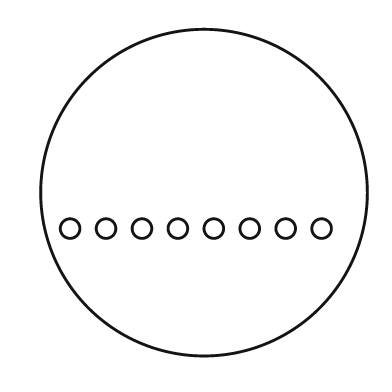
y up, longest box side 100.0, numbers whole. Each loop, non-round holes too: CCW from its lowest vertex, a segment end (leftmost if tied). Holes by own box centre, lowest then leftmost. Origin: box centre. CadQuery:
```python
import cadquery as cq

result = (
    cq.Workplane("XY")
    .moveTo(0.0, 0.0)
    .circle(50.0)
    .moveTo(-41.0, -11.0)
    .circle(3.0)
    .moveTo(-30.0, -11.0)
    .circle(3.0)
    .moveTo(-19.0, -11.0)
    .circle(3.0)
    .moveTo(-8.0, -11.0)
    .circle(3.0)
    .moveTo(3.0, -11.0)
    .circle(3.0)
    .moveTo(14.0, -11.0)
    .circle(3.0)
    .moveTo(25.0, -11.0)
    .circle(3.0)
    .moveTo(36.0, -11.0)
    .circle(3.0)
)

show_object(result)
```